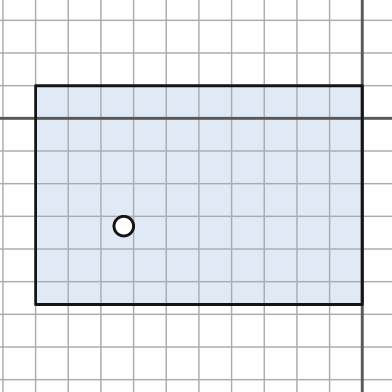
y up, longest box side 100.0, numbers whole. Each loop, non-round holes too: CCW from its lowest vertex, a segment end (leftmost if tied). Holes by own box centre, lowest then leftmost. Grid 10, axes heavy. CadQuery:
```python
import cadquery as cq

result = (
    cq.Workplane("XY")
    .moveTo(-100.0, -57.0)
    .lineTo(0.0, -57.0)
    .lineTo(0.0, 10.0)
    .lineTo(-100.0, 10.0)
    .close()
    .moveTo(-73.0, -33.0)
    .circle(3.0)
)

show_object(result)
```